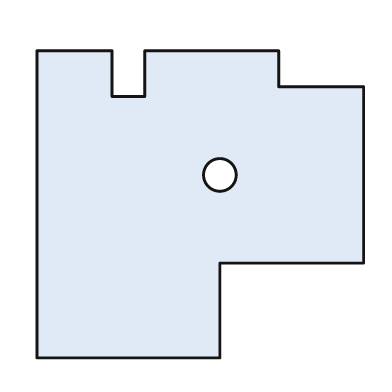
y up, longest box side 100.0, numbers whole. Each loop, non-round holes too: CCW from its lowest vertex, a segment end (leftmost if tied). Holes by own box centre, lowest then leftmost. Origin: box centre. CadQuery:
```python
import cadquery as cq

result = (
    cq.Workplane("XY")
    .moveTo(-50.0, -47.0)
    .lineTo(6.0, -47.0)
    .lineTo(6.0, -18.0)
    .lineTo(50.0, -18.0)
    .lineTo(50.0, 36.0)
    .lineTo(24.0, 36.0)
    .lineTo(24.0, 47.0)
    .lineTo(-17.0, 47.0)
    .lineTo(-17.0, 33.0)
    .lineTo(-27.0, 33.0)
    .lineTo(-27.0, 47.0)
    .lineTo(-50.0, 47.0)
    .close()
    .moveTo(6.0, 9.0)
    .circle(5.0)
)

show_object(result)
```